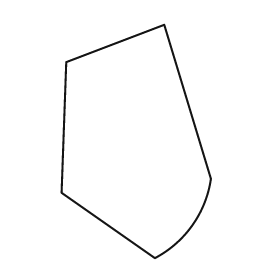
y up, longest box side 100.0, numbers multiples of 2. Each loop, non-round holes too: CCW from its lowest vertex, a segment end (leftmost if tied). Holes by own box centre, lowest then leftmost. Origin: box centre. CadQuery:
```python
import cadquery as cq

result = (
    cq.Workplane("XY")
    .moveTo(8.0, -50.0)
    .threePointArc((24.0, -36.0), (32.0, -16.0))
    .lineTo(12.0, 50.0)
    .lineTo(-30.0, 34.0)
    .lineTo(-32.0, -22.0)
    .close()
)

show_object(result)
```